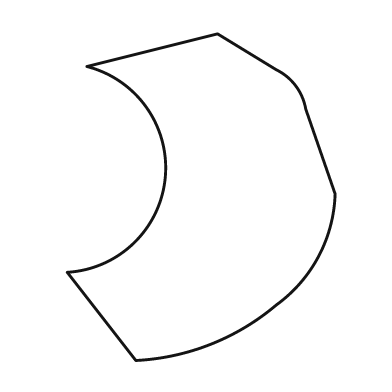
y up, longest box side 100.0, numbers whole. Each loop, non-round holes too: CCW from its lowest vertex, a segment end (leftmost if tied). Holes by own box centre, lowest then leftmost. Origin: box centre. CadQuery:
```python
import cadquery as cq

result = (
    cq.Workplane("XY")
    .moveTo(-20.0, -50.0)
    .threePointArc((3.0, -45.0), (23.0, -33.0))
    .threePointArc((36.0, -18.0), (41.0, 1.0))
    .lineTo(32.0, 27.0)
    .threePointArc((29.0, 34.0), (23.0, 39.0))
    .lineTo(5.0, 50.0)
    .lineTo(-35.0, 40.0)
    .threePointArc((-11.0, 6.0), (-41.0, -23.0))
    .close()
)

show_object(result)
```